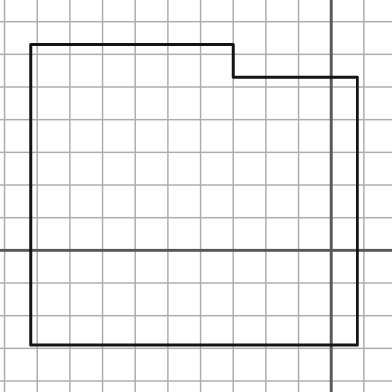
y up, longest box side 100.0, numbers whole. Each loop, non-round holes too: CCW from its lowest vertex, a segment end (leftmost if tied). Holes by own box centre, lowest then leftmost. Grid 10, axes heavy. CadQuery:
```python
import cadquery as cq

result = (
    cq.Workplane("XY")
    .moveTo(-92.0, -29.0)
    .lineTo(8.0, -29.0)
    .lineTo(8.0, 53.0)
    .lineTo(-30.0, 53.0)
    .lineTo(-30.0, 63.0)
    .lineTo(-92.0, 63.0)
    .close()
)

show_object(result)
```